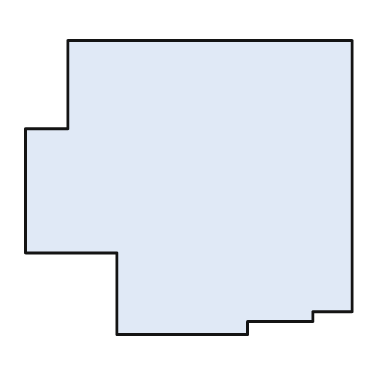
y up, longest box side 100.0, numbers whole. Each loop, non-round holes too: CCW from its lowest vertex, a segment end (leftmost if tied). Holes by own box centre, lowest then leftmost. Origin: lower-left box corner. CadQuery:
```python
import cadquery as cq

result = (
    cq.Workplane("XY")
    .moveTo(28.0, 0.0)
    .lineTo(68.0, 0.0)
    .lineTo(68.0, 4.0)
    .lineTo(88.0, 4.0)
    .lineTo(88.0, 7.0)
    .lineTo(100.0, 7.0)
    .lineTo(100.0, 90.0)
    .lineTo(13.0, 90.0)
    .lineTo(13.0, 63.0)
    .lineTo(0.0, 63.0)
    .lineTo(0.0, 25.0)
    .lineTo(28.0, 25.0)
    .close()
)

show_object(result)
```